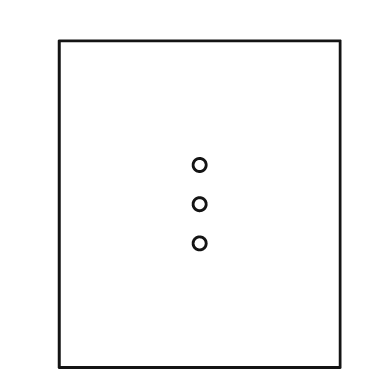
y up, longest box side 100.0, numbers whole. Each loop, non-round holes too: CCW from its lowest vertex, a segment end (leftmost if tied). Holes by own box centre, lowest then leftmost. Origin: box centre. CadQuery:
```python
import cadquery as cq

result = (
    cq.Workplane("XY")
    .moveTo(-43.0, -50.0)
    .lineTo(43.0, -50.0)
    .lineTo(43.0, 50.0)
    .lineTo(-43.0, 50.0)
    .close()
    .moveTo(0.0, -12.0)
    .circle(2.0)
    .moveTo(0.0, 0.0)
    .circle(2.0)
    .moveTo(0.0, 12.0)
    .circle(2.0)
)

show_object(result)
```